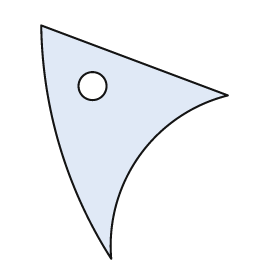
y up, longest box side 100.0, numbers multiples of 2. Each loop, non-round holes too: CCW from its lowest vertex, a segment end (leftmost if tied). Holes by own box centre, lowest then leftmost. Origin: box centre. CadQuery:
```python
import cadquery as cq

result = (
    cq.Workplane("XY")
    .moveTo(-10.0, -50.0)
    .threePointArc((2.0, -6.0), (40.0, 20.0))
    .lineTo(-40.0, 50.0)
    .threePointArc((-32.0, -2.0), (-10.0, -50.0))
    .close()
    .moveTo(-18.0, 24.0)
    .circle(6.0)
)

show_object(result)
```